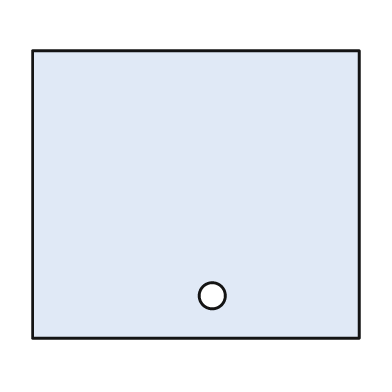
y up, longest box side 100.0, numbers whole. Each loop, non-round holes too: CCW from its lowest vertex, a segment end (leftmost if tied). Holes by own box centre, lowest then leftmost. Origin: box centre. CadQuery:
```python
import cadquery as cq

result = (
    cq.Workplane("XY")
    .moveTo(-50.0, -44.0)
    .lineTo(50.0, -44.0)
    .lineTo(50.0, 44.0)
    .lineTo(-50.0, 44.0)
    .close()
    .moveTo(5.0, -31.0)
    .circle(4.0)
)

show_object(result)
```